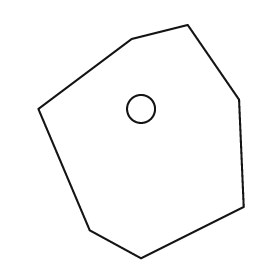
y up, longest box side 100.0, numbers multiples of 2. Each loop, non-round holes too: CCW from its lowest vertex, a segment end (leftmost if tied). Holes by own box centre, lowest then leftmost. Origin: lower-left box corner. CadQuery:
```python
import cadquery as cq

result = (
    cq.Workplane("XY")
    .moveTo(44.0, 0.0)
    .lineTo(88.0, 22.0)
    .lineTo(86.0, 68.0)
    .lineTo(64.0, 100.0)
    .lineTo(40.0, 94.0)
    .lineTo(0.0, 64.0)
    .lineTo(22.0, 12.0)
    .close()
    .moveTo(44.0, 64.0)
    .circle(6.0)
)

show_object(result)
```